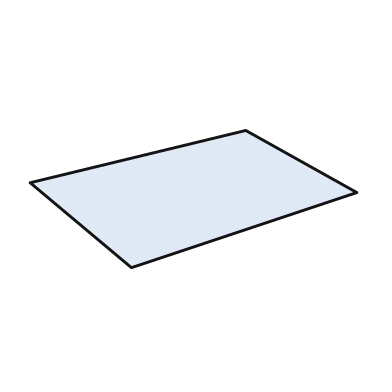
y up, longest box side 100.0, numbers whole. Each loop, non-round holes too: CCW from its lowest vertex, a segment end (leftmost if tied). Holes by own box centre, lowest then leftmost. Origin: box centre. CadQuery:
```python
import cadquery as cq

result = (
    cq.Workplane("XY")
    .moveTo(-19.0, -21.0)
    .lineTo(50.0, 2.0)
    .lineTo(16.0, 21.0)
    .lineTo(-50.0, 5.0)
    .close()
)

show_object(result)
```